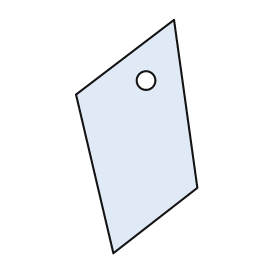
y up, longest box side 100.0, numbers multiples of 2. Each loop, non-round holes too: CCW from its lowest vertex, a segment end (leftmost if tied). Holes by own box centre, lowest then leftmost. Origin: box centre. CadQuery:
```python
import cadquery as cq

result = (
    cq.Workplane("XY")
    .moveTo(-10.0, -50.0)
    .lineTo(26.0, -22.0)
    .lineTo(16.0, 50.0)
    .lineTo(-26.0, 18.0)
    .close()
    .moveTo(4.0, 24.0)
    .circle(4.0)
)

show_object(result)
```